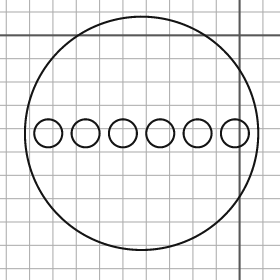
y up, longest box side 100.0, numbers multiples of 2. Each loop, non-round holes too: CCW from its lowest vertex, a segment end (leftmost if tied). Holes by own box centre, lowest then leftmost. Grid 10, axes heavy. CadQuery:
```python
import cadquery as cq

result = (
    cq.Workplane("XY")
    .moveTo(-42.0, -42.0)
    .circle(50.0)
    .moveTo(-82.0, -42.0)
    .circle(6.0)
    .moveTo(-66.0, -42.0)
    .circle(6.0)
    .moveTo(-50.0, -42.0)
    .circle(6.0)
    .moveTo(-34.0, -42.0)
    .circle(6.0)
    .moveTo(-18.0, -42.0)
    .circle(6.0)
    .moveTo(-2.0, -42.0)
    .circle(6.0)
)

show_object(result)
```